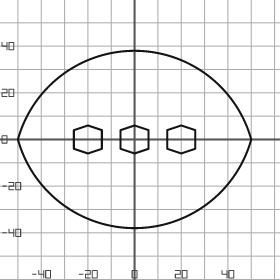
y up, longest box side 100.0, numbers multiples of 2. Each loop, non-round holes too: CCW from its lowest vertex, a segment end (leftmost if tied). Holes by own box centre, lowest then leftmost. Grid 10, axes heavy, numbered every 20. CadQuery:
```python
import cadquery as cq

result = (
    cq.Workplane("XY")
    .moveTo(-50.0, 0.0)
    .threePointArc((0.0, -38.0), (50.0, 0.0))
    .threePointArc((0.0, 38.0), (-50.0, 0.0))
    .close()
    .moveTo(-20.0, -6.0)
    .lineTo(-14.0, -4.0)
    .lineTo(-14.0, 4.0)
    .lineTo(-20.0, 6.0)
    .lineTo(-26.0, 4.0)
    .lineTo(-26.0, -4.0)
    .close()
    .moveTo(0.0, -6.0)
    .lineTo(6.0, -4.0)
    .lineTo(6.0, 4.0)
    .lineTo(0.0, 6.0)
    .lineTo(-6.0, 4.0)
    .lineTo(-6.0, -4.0)
    .close()
    .moveTo(20.0, -6.0)
    .lineTo(26.0, -4.0)
    .lineTo(26.0, 4.0)
    .lineTo(20.0, 6.0)
    .lineTo(14.0, 4.0)
    .lineTo(14.0, -4.0)
    .close()
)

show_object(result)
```